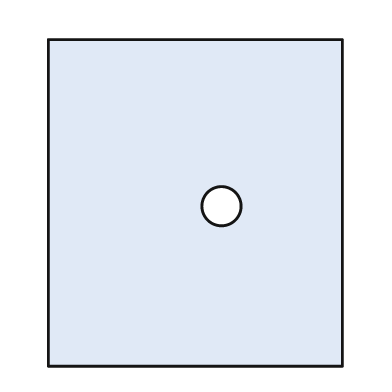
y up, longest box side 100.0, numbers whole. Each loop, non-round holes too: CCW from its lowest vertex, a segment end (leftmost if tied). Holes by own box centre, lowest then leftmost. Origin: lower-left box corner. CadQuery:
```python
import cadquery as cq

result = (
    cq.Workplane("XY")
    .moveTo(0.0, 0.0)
    .lineTo(90.0, 0.0)
    .lineTo(90.0, 100.0)
    .lineTo(0.0, 100.0)
    .close()
    .moveTo(53.0, 49.0)
    .circle(6.0)
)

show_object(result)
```